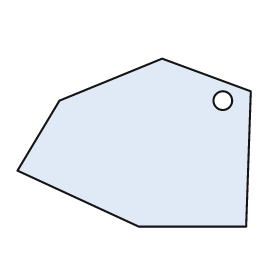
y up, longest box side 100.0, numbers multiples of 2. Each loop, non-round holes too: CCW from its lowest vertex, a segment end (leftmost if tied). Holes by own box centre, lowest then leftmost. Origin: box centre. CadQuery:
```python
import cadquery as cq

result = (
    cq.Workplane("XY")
    .moveTo(2.0, -36.0)
    .lineTo(48.0, -36.0)
    .lineTo(50.0, 22.0)
    .lineTo(12.0, 36.0)
    .lineTo(-32.0, 18.0)
    .lineTo(-50.0, -12.0)
    .close()
    .moveTo(38.0, 18.0)
    .circle(4.0)
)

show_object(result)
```